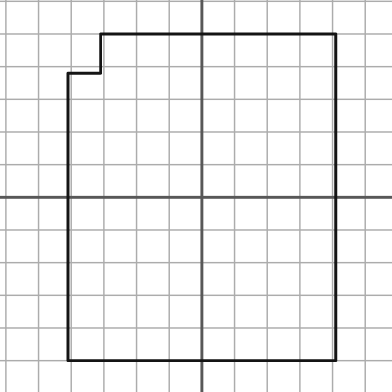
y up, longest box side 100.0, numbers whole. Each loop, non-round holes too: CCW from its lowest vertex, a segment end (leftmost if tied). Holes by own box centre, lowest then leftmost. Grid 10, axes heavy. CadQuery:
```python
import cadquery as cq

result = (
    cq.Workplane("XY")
    .moveTo(-41.0, -50.0)
    .lineTo(41.0, -50.0)
    .lineTo(41.0, 50.0)
    .lineTo(-31.0, 50.0)
    .lineTo(-31.0, 38.0)
    .lineTo(-41.0, 38.0)
    .close()
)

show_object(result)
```